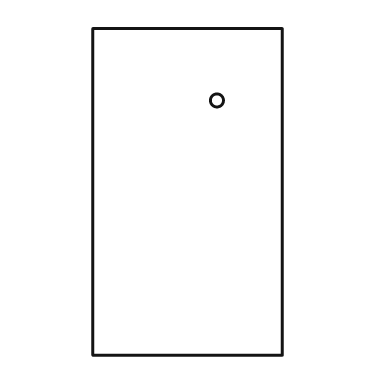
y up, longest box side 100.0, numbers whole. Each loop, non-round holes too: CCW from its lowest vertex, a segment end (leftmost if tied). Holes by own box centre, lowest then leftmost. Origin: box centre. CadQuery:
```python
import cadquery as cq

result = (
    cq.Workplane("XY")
    .moveTo(-29.0, -50.0)
    .lineTo(29.0, -50.0)
    .lineTo(29.0, 50.0)
    .lineTo(-29.0, 50.0)
    .close()
    .moveTo(9.0, 28.0)
    .circle(2.0)
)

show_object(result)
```